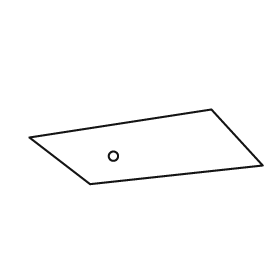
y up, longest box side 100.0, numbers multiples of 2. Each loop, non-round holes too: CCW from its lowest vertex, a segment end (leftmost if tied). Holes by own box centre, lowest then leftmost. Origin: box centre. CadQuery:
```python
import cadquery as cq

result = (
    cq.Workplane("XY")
    .moveTo(-24.0, -16.0)
    .lineTo(50.0, -8.0)
    .lineTo(28.0, 16.0)
    .lineTo(-50.0, 4.0)
    .close()
    .moveTo(-14.0, -4.0)
    .circle(2.0)
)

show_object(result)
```